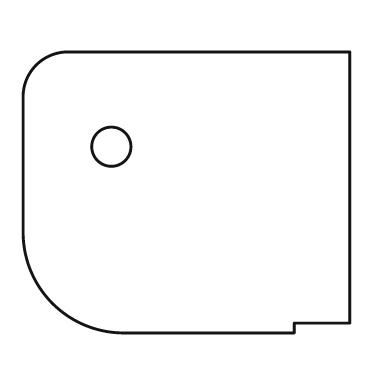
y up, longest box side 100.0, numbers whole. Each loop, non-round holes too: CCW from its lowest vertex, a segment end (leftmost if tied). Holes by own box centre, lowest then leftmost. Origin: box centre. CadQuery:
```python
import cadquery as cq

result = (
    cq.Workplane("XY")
    .moveTo(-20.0, -43.0)
    .lineTo(33.0, -43.0)
    .lineTo(33.0, -40.0)
    .lineTo(50.0, -40.0)
    .lineTo(50.0, 43.0)
    .lineTo(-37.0, 43.0)
    .threePointArc((-46.0, 39.0), (-50.0, 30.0))
    .lineTo(-50.0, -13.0)
    .threePointArc((-41.0, -34.0), (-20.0, -43.0))
    .close()
    .moveTo(-23.0, 14.0)
    .circle(6.0)
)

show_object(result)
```